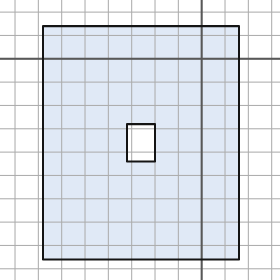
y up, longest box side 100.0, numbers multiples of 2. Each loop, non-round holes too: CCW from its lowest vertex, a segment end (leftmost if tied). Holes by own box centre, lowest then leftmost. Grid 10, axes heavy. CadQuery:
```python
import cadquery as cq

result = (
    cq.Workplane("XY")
    .moveTo(-68.0, -86.0)
    .lineTo(16.0, -86.0)
    .lineTo(16.0, 14.0)
    .lineTo(-68.0, 14.0)
    .close()
    .moveTo(-32.0, -44.0)
    .lineTo(-20.0, -44.0)
    .lineTo(-20.0, -28.0)
    .lineTo(-32.0, -28.0)
    .close()
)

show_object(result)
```